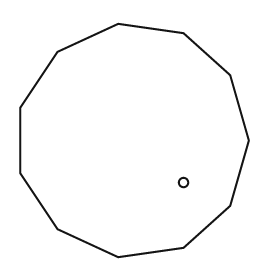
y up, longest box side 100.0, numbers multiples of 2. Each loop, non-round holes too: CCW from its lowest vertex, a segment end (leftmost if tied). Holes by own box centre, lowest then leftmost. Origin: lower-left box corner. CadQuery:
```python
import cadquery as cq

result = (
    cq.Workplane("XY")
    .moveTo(42.0, 0.0)
    .lineTo(70.0, 4.0)
    .lineTo(90.0, 22.0)
    .lineTo(98.0, 50.0)
    .lineTo(90.0, 78.0)
    .lineTo(70.0, 96.0)
    .lineTo(42.0, 100.0)
    .lineTo(16.0, 88.0)
    .lineTo(0.0, 64.0)
    .lineTo(0.0, 36.0)
    .lineTo(16.0, 12.0)
    .close()
    .moveTo(70.0, 32.0)
    .circle(2.0)
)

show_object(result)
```